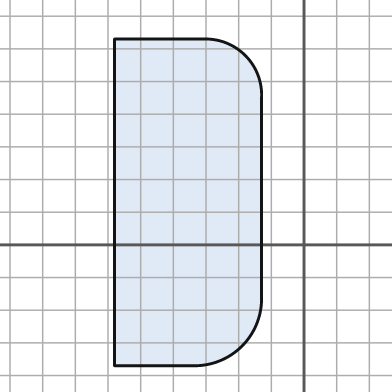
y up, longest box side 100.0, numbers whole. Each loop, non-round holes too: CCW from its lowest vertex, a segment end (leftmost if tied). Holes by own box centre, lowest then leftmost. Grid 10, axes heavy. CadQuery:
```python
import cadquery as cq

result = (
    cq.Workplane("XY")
    .moveTo(-58.0, -37.0)
    .lineTo(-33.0, -37.0)
    .threePointArc((-19.0, -31.0), (-13.0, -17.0))
    .lineTo(-13.0, 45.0)
    .threePointArc((-18.0, 58.0), (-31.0, 63.0))
    .lineTo(-58.0, 63.0)
    .close()
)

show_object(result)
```